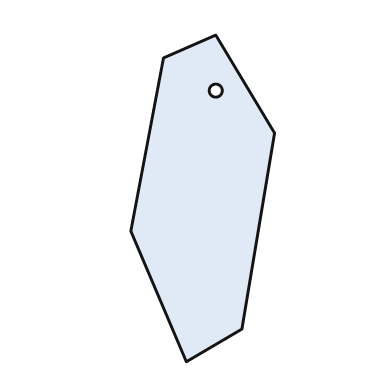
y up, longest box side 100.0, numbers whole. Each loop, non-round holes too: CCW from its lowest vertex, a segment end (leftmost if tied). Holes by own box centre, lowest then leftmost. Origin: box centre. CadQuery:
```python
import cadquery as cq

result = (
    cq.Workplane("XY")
    .moveTo(-5.0, -50.0)
    .lineTo(12.0, -40.0)
    .lineTo(22.0, 20.0)
    .lineTo(4.0, 50.0)
    .lineTo(-12.0, 43.0)
    .lineTo(-22.0, -10.0)
    .close()
    .moveTo(4.0, 33.0)
    .circle(2.0)
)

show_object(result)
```